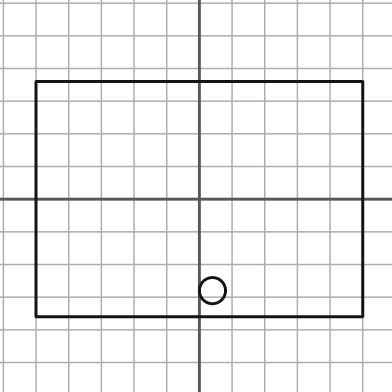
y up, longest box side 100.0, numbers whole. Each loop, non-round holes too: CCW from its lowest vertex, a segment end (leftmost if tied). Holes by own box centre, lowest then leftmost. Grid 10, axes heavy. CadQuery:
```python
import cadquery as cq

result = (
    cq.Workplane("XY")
    .moveTo(-50.0, -36.0)
    .lineTo(50.0, -36.0)
    .lineTo(50.0, 36.0)
    .lineTo(-50.0, 36.0)
    .close()
    .moveTo(4.0, -28.0)
    .circle(4.0)
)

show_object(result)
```